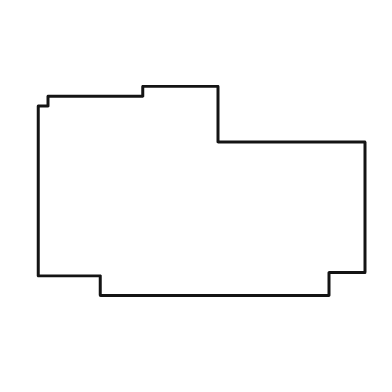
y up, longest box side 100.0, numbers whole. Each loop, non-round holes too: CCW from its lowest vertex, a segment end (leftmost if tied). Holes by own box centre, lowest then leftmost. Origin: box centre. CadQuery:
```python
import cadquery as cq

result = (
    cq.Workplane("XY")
    .moveTo(-31.0, -32.0)
    .lineTo(39.0, -32.0)
    .lineTo(39.0, -25.0)
    .lineTo(50.0, -25.0)
    .lineTo(50.0, 15.0)
    .lineTo(5.0, 15.0)
    .lineTo(5.0, 32.0)
    .lineTo(-18.0, 32.0)
    .lineTo(-18.0, 29.0)
    .lineTo(-47.0, 29.0)
    .lineTo(-47.0, 26.0)
    .lineTo(-50.0, 26.0)
    .lineTo(-50.0, -26.0)
    .lineTo(-31.0, -26.0)
    .close()
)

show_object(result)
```